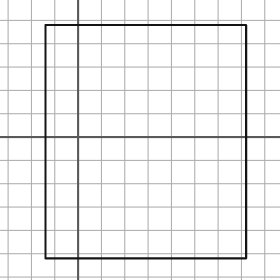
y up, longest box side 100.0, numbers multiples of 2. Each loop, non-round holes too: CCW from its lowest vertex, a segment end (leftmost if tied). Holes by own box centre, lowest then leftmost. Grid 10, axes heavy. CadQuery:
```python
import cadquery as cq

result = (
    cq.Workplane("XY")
    .moveTo(-14.0, -52.0)
    .lineTo(72.0, -52.0)
    .lineTo(72.0, 48.0)
    .lineTo(-14.0, 48.0)
    .close()
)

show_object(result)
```